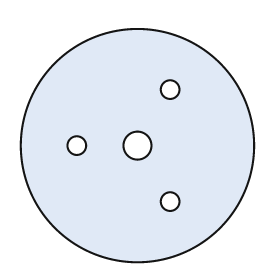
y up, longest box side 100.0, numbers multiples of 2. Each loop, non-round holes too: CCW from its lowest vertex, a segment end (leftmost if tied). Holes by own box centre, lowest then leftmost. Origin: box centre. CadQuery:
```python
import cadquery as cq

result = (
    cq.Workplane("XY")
    .moveTo(0.0, 0.0)
    .circle(50.0)
    .moveTo(14.0, -24.0)
    .circle(4.0)
    .moveTo(-26.0, 0.0)
    .circle(4.0)
    .moveTo(0.0, 0.0)
    .circle(6.0)
    .moveTo(14.0, 24.0)
    .circle(4.0)
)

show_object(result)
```